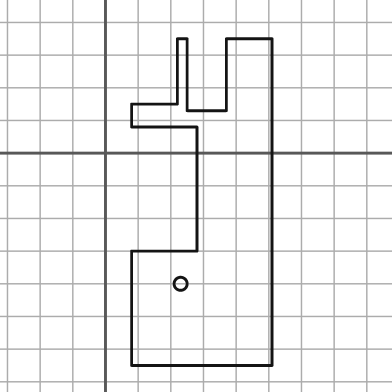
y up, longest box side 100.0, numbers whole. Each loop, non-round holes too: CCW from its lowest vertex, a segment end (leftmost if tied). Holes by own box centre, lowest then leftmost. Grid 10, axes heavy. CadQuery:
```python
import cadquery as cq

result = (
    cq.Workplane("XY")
    .moveTo(8.0, -65.0)
    .lineTo(51.0, -65.0)
    .lineTo(51.0, 35.0)
    .lineTo(37.0, 35.0)
    .lineTo(37.0, 13.0)
    .lineTo(25.0, 13.0)
    .lineTo(25.0, 35.0)
    .lineTo(22.0, 35.0)
    .lineTo(22.0, 15.0)
    .lineTo(8.0, 15.0)
    .lineTo(8.0, 8.0)
    .lineTo(28.0, 8.0)
    .lineTo(28.0, -30.0)
    .lineTo(8.0, -30.0)
    .close()
    .moveTo(23.0, -40.0)
    .circle(2.0)
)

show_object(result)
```